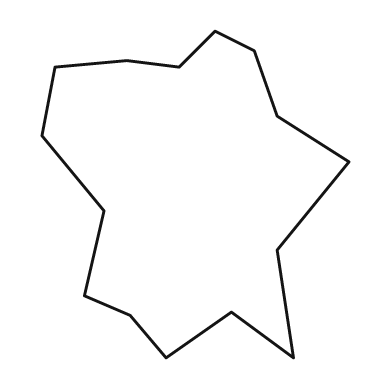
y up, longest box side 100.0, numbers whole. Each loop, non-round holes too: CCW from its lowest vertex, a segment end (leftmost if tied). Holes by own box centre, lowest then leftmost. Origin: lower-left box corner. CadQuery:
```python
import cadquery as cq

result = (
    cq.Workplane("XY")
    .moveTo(38.0, 0.0)
    .lineTo(58.0, 14.0)
    .lineTo(77.0, 0.0)
    .lineTo(72.0, 33.0)
    .lineTo(94.0, 60.0)
    .lineTo(72.0, 74.0)
    .lineTo(65.0, 94.0)
    .lineTo(53.0, 100.0)
    .lineTo(42.0, 89.0)
    .lineTo(26.0, 91.0)
    .lineTo(4.0, 89.0)
    .lineTo(0.0, 68.0)
    .lineTo(19.0, 45.0)
    .lineTo(13.0, 19.0)
    .lineTo(27.0, 13.0)
    .close()
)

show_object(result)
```